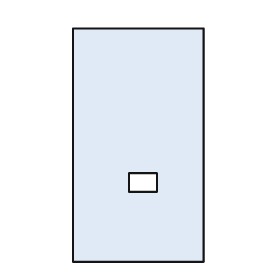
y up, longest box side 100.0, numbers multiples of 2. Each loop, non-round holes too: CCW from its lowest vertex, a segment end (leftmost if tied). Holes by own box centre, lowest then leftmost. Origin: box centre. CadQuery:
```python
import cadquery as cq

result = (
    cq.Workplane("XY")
    .moveTo(-28.0, -50.0)
    .lineTo(28.0, -50.0)
    .lineTo(28.0, 50.0)
    .lineTo(-28.0, 50.0)
    .close()
    .moveTo(-4.0, -20.0)
    .lineTo(8.0, -20.0)
    .lineTo(8.0, -12.0)
    .lineTo(-4.0, -12.0)
    .close()
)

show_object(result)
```